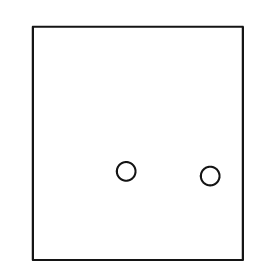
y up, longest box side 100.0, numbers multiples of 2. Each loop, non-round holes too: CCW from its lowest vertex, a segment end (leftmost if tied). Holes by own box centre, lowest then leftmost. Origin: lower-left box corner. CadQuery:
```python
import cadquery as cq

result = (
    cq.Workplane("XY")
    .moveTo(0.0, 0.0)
    .lineTo(90.0, 0.0)
    .lineTo(90.0, 100.0)
    .lineTo(0.0, 100.0)
    .close()
    .moveTo(76.0, 36.0)
    .circle(4.0)
    .moveTo(40.0, 38.0)
    .circle(4.0)
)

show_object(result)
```